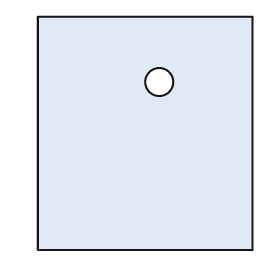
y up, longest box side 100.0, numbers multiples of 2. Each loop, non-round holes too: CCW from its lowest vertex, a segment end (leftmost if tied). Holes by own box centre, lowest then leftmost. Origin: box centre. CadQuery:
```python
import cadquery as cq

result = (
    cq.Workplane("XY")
    .moveTo(-46.0, -50.0)
    .lineTo(46.0, -50.0)
    .lineTo(46.0, 50.0)
    .lineTo(-46.0, 50.0)
    .close()
    .moveTo(6.0, 22.0)
    .circle(6.0)
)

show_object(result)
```